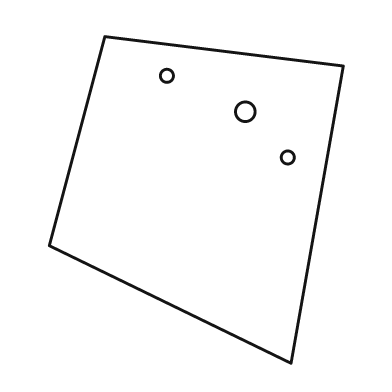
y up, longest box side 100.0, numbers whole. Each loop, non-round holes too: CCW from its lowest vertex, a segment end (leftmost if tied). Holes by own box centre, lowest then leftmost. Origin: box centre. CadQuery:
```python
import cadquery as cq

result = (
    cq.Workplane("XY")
    .moveTo(29.0, -50.0)
    .lineTo(45.0, 41.0)
    .lineTo(-28.0, 50.0)
    .lineTo(-45.0, -14.0)
    .close()
    .moveTo(28.0, 13.0)
    .circle(2.0)
    .moveTo(15.0, 27.0)
    .circle(3.0)
    .moveTo(-9.0, 38.0)
    .circle(2.0)
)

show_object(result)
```